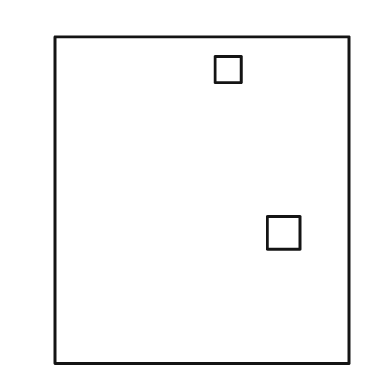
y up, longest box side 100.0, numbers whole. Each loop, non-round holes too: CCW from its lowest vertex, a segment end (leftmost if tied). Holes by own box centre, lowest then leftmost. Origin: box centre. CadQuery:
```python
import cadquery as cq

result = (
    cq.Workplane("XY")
    .moveTo(-45.0, -50.0)
    .lineTo(45.0, -50.0)
    .lineTo(45.0, 50.0)
    .lineTo(-45.0, 50.0)
    .close()
    .moveTo(20.0, -15.0)
    .lineTo(30.0, -15.0)
    .lineTo(30.0, -5.0)
    .lineTo(20.0, -5.0)
    .close()
    .moveTo(4.0, 36.0)
    .lineTo(12.0, 36.0)
    .lineTo(12.0, 44.0)
    .lineTo(4.0, 44.0)
    .close()
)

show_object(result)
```